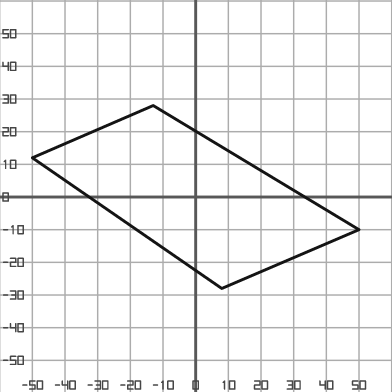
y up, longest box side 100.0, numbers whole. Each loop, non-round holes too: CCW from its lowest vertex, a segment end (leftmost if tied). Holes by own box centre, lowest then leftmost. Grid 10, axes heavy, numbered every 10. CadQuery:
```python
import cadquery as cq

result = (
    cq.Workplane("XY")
    .moveTo(8.0, -28.0)
    .lineTo(50.0, -10.0)
    .lineTo(-13.0, 28.0)
    .lineTo(-50.0, 12.0)
    .close()
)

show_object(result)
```